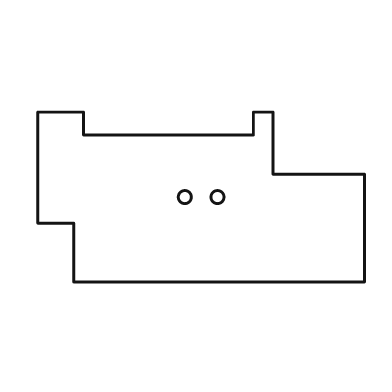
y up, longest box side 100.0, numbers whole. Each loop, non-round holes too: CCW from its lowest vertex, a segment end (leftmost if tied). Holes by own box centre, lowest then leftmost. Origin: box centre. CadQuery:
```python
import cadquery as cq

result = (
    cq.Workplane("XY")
    .moveTo(-39.0, -26.0)
    .lineTo(50.0, -26.0)
    .lineTo(50.0, 7.0)
    .lineTo(22.0, 7.0)
    .lineTo(22.0, 26.0)
    .lineTo(16.0, 26.0)
    .lineTo(16.0, 19.0)
    .lineTo(-36.0, 19.0)
    .lineTo(-36.0, 26.0)
    .lineTo(-50.0, 26.0)
    .lineTo(-50.0, -8.0)
    .lineTo(-39.0, -8.0)
    .close()
    .moveTo(-5.0, 0.0)
    .circle(2.0)
    .moveTo(5.0, 0.0)
    .circle(2.0)
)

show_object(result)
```